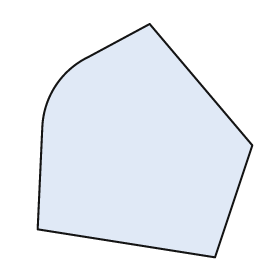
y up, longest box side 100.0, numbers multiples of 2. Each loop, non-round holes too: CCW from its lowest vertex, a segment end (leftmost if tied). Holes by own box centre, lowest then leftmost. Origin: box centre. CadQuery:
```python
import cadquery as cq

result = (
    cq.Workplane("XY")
    .moveTo(30.0, -50.0)
    .lineTo(46.0, -2.0)
    .lineTo(2.0, 50.0)
    .lineTo(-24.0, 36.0)
    .threePointArc((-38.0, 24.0), (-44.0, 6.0))
    .lineTo(-46.0, -38.0)
    .close()
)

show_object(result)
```